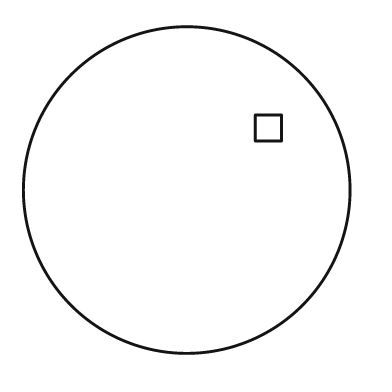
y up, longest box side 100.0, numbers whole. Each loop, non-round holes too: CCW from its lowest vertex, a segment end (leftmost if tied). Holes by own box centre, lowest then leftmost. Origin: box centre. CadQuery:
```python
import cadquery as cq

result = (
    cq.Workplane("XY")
    .moveTo(0.0, 0.0)
    .circle(50.0)
    .moveTo(21.0, 15.0)
    .lineTo(29.0, 15.0)
    .lineTo(29.0, 23.0)
    .lineTo(21.0, 23.0)
    .close()
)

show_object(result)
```